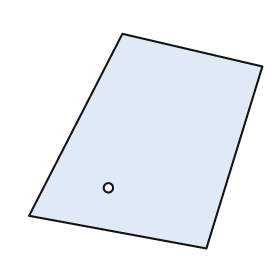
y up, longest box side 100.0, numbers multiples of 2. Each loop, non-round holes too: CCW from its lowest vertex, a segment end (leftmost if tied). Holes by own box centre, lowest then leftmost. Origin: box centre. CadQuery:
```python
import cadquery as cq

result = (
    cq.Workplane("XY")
    .moveTo(26.0, -46.0)
    .lineTo(50.0, 32.0)
    .lineTo(-10.0, 46.0)
    .lineTo(-50.0, -32.0)
    .close()
    .moveTo(-16.0, -20.0)
    .circle(2.0)
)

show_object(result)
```